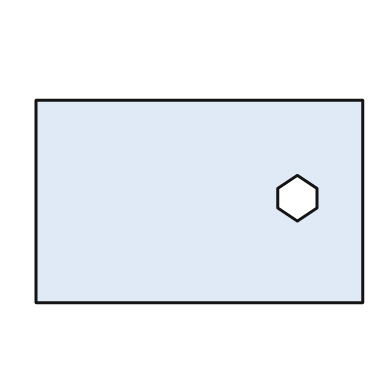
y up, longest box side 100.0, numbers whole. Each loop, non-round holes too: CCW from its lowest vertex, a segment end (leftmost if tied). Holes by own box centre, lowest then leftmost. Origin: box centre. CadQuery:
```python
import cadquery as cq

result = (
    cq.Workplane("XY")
    .moveTo(-50.0, -31.0)
    .lineTo(50.0, -31.0)
    .lineTo(50.0, 31.0)
    .lineTo(-50.0, 31.0)
    .close()
    .moveTo(30.0, -6.0)
    .lineTo(36.0, -2.0)
    .lineTo(36.0, 4.0)
    .lineTo(30.0, 8.0)
    .lineTo(24.0, 4.0)
    .lineTo(24.0, -2.0)
    .close()
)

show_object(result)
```